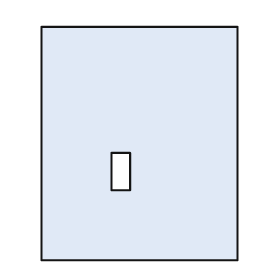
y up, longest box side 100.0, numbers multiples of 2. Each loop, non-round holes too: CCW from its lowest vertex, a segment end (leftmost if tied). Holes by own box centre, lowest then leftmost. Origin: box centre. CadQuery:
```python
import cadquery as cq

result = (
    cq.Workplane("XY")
    .moveTo(-42.0, -50.0)
    .lineTo(42.0, -50.0)
    .lineTo(42.0, 50.0)
    .lineTo(-42.0, 50.0)
    .close()
    .moveTo(-12.0, -20.0)
    .lineTo(-4.0, -20.0)
    .lineTo(-4.0, -4.0)
    .lineTo(-12.0, -4.0)
    .close()
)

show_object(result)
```